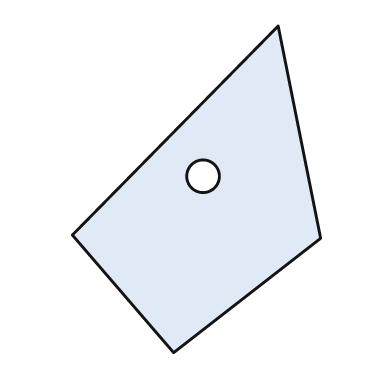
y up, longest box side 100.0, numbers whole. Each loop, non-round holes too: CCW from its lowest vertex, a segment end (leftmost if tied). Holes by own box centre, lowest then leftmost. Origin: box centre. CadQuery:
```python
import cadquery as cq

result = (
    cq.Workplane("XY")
    .moveTo(-7.0, -50.0)
    .lineTo(38.0, -15.0)
    .lineTo(25.0, 50.0)
    .lineTo(-38.0, -14.0)
    .close()
    .moveTo(2.0, 4.0)
    .circle(5.0)
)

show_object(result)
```